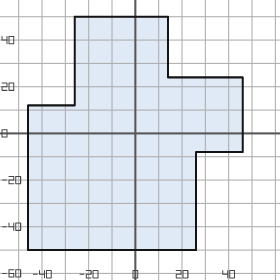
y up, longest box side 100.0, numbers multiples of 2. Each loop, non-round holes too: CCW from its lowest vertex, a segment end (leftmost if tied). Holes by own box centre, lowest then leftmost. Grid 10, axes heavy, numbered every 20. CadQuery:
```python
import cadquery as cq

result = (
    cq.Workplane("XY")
    .moveTo(-46.0, -50.0)
    .lineTo(26.0, -50.0)
    .lineTo(26.0, -8.0)
    .lineTo(46.0, -8.0)
    .lineTo(46.0, 24.0)
    .lineTo(14.0, 24.0)
    .lineTo(14.0, 50.0)
    .lineTo(-26.0, 50.0)
    .lineTo(-26.0, 12.0)
    .lineTo(-46.0, 12.0)
    .close()
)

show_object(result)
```